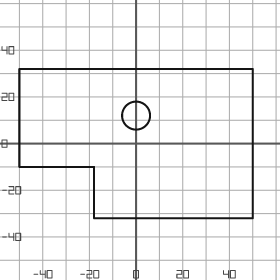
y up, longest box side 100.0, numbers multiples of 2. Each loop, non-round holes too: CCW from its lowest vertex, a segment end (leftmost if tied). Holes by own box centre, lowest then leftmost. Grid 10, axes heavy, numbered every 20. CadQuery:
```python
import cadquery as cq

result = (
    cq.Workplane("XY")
    .moveTo(-18.0, -32.0)
    .lineTo(50.0, -32.0)
    .lineTo(50.0, 32.0)
    .lineTo(-50.0, 32.0)
    .lineTo(-50.0, -10.0)
    .lineTo(-18.0, -10.0)
    .close()
    .moveTo(0.0, 12.0)
    .circle(6.0)
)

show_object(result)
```